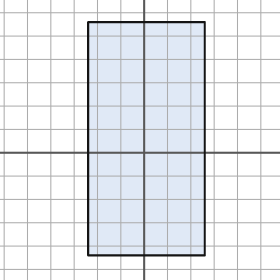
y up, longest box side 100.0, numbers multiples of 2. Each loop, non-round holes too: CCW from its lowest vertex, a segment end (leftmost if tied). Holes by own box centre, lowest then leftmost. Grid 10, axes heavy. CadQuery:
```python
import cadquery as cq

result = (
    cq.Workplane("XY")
    .moveTo(-24.0, -44.0)
    .lineTo(26.0, -44.0)
    .lineTo(26.0, 56.0)
    .lineTo(-24.0, 56.0)
    .close()
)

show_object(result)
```